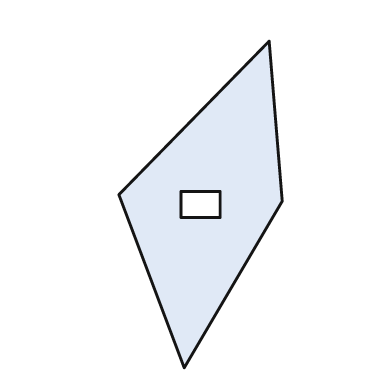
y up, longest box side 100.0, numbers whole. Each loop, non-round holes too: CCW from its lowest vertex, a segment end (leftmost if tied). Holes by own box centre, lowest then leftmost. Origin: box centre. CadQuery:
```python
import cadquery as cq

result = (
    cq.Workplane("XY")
    .moveTo(-5.0, -50.0)
    .lineTo(25.0, 1.0)
    .lineTo(21.0, 50.0)
    .lineTo(-25.0, 3.0)
    .close()
    .moveTo(-6.0, -4.0)
    .lineTo(6.0, -4.0)
    .lineTo(6.0, 4.0)
    .lineTo(-6.0, 4.0)
    .close()
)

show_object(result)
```